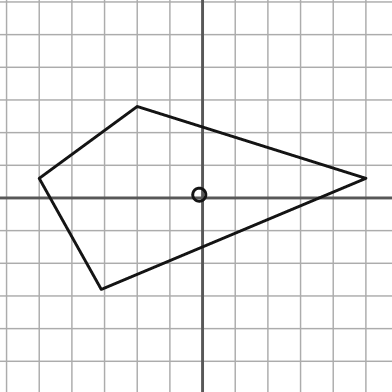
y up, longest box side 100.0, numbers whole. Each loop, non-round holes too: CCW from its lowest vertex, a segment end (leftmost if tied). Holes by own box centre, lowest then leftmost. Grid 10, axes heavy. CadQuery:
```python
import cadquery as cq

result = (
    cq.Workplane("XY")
    .moveTo(-31.0, -28.0)
    .lineTo(50.0, 6.0)
    .lineTo(-20.0, 28.0)
    .lineTo(-50.0, 6.0)
    .close()
    .moveTo(-1.0, 1.0)
    .circle(2.0)
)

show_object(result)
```